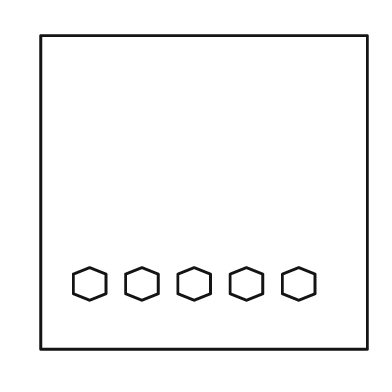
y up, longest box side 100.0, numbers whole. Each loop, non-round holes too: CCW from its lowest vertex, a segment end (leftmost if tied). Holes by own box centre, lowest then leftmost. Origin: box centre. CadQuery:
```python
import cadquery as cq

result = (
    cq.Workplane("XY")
    .moveTo(-50.0, -48.0)
    .lineTo(50.0, -48.0)
    .lineTo(50.0, 48.0)
    .lineTo(-50.0, 48.0)
    .close()
    .moveTo(-35.0, -33.0)
    .lineTo(-30.0, -31.0)
    .lineTo(-30.0, -25.0)
    .lineTo(-35.0, -23.0)
    .lineTo(-40.0, -25.0)
    .lineTo(-40.0, -31.0)
    .close()
    .moveTo(-19.0, -33.0)
    .lineTo(-14.0, -31.0)
    .lineTo(-14.0, -25.0)
    .lineTo(-19.0, -23.0)
    .lineTo(-24.0, -25.0)
    .lineTo(-24.0, -31.0)
    .close()
    .moveTo(-3.0, -33.0)
    .lineTo(2.0, -31.0)
    .lineTo(2.0, -25.0)
    .lineTo(-3.0, -23.0)
    .lineTo(-8.0, -25.0)
    .lineTo(-8.0, -31.0)
    .close()
    .moveTo(13.0, -33.0)
    .lineTo(18.0, -31.0)
    .lineTo(18.0, -25.0)
    .lineTo(13.0, -23.0)
    .lineTo(8.0, -25.0)
    .lineTo(8.0, -31.0)
    .close()
    .moveTo(29.0, -33.0)
    .lineTo(34.0, -31.0)
    .lineTo(34.0, -25.0)
    .lineTo(29.0, -23.0)
    .lineTo(24.0, -25.0)
    .lineTo(24.0, -31.0)
    .close()
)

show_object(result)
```